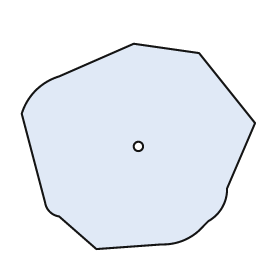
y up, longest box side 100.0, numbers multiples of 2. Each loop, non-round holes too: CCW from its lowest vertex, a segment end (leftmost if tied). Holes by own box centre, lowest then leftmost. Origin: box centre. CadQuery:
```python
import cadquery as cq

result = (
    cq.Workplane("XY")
    .moveTo(-18.0, -44.0)
    .lineTo(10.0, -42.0)
    .threePointArc((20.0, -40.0), (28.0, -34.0))
    .lineTo(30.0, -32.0)
    .threePointArc((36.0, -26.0), (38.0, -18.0))
    .lineTo(50.0, 10.0)
    .lineTo(26.0, 40.0)
    .lineTo(-2.0, 44.0)
    .lineTo(-34.0, 30.0)
    .threePointArc((-44.0, 24.0), (-50.0, 14.0))
    .lineTo(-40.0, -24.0)
    .threePointArc((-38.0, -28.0), (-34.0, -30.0))
    .close()
    .moveTo(0.0, 0.0)
    .circle(2.0)
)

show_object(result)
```